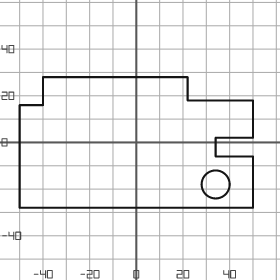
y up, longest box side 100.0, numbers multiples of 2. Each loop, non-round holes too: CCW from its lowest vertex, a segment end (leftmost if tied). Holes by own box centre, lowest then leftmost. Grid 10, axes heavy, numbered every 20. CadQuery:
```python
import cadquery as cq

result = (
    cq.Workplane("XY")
    .moveTo(-50.0, -28.0)
    .lineTo(50.0, -28.0)
    .lineTo(50.0, -6.0)
    .lineTo(34.0, -6.0)
    .lineTo(34.0, 2.0)
    .lineTo(50.0, 2.0)
    .lineTo(50.0, 18.0)
    .lineTo(22.0, 18.0)
    .lineTo(22.0, 28.0)
    .lineTo(-40.0, 28.0)
    .lineTo(-40.0, 16.0)
    .lineTo(-50.0, 16.0)
    .close()
    .moveTo(34.0, -18.0)
    .circle(6.0)
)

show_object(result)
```